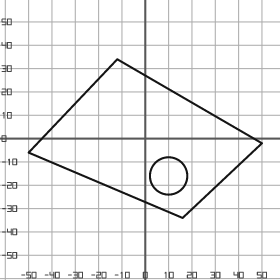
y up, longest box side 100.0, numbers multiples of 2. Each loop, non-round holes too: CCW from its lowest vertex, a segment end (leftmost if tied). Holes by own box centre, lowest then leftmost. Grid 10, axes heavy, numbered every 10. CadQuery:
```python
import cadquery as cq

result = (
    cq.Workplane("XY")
    .moveTo(16.0, -34.0)
    .lineTo(50.0, -2.0)
    .lineTo(-12.0, 34.0)
    .lineTo(-50.0, -6.0)
    .close()
    .moveTo(10.0, -16.0)
    .circle(8.0)
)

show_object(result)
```